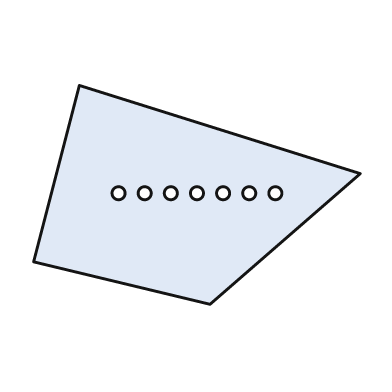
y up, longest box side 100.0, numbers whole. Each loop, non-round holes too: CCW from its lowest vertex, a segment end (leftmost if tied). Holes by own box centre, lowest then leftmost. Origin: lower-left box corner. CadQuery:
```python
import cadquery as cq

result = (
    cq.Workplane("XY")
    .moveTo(54.0, 0.0)
    .lineTo(100.0, 40.0)
    .lineTo(14.0, 67.0)
    .lineTo(0.0, 13.0)
    .close()
    .moveTo(26.0, 34.0)
    .circle(2.0)
    .moveTo(34.0, 34.0)
    .circle(2.0)
    .moveTo(42.0, 34.0)
    .circle(2.0)
    .moveTo(50.0, 34.0)
    .circle(2.0)
    .moveTo(58.0, 34.0)
    .circle(2.0)
    .moveTo(66.0, 34.0)
    .circle(2.0)
    .moveTo(74.0, 34.0)
    .circle(2.0)
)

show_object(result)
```